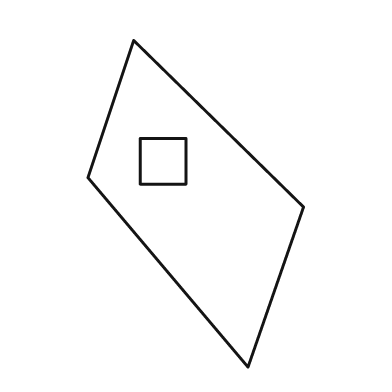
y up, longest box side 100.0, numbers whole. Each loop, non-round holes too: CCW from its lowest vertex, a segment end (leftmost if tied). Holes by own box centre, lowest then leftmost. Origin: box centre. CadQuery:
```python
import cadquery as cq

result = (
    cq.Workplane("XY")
    .moveTo(16.0, -50.0)
    .lineTo(33.0, -1.0)
    .lineTo(-19.0, 50.0)
    .lineTo(-33.0, 8.0)
    .close()
    .moveTo(-17.0, 6.0)
    .lineTo(-3.0, 6.0)
    .lineTo(-3.0, 20.0)
    .lineTo(-17.0, 20.0)
    .close()
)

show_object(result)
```